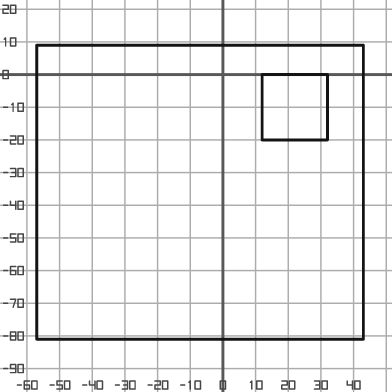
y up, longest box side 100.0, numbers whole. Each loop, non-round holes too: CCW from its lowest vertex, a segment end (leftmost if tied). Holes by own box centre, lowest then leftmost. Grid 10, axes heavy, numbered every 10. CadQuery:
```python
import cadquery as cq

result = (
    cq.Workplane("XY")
    .moveTo(-57.0, -81.0)
    .lineTo(43.0, -81.0)
    .lineTo(43.0, 9.0)
    .lineTo(-57.0, 9.0)
    .close()
    .moveTo(12.0, -20.0)
    .lineTo(32.0, -20.0)
    .lineTo(32.0, 0.0)
    .lineTo(12.0, 0.0)
    .close()
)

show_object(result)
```